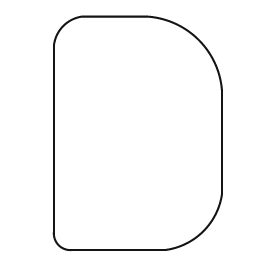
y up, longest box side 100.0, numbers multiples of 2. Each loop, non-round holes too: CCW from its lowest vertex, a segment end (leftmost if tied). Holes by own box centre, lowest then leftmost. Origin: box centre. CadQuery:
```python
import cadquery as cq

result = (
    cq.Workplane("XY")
    .moveTo(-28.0, -50.0)
    .lineTo(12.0, -50.0)
    .threePointArc((28.0, -42.0), (36.0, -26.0))
    .lineTo(36.0, 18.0)
    .threePointArc((26.0, 40.0), (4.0, 50.0))
    .lineTo(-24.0, 50.0)
    .threePointArc((-32.0, 46.0), (-36.0, 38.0))
    .lineTo(-36.0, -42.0)
    .threePointArc((-34.0, -48.0), (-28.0, -50.0))
    .close()
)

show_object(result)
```